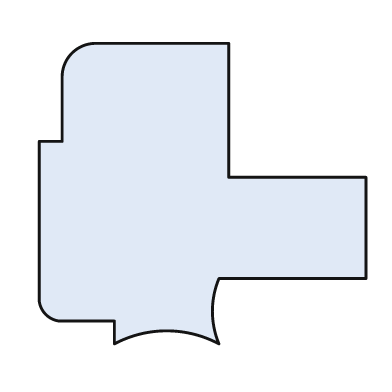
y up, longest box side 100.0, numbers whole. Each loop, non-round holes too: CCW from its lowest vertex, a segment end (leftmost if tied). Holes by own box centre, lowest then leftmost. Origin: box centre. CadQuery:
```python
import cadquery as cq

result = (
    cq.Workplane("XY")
    .moveTo(-27.0, -46.0)
    .threePointArc((-11.0, -42.0), (5.0, -46.0))
    .threePointArc((3.0, -36.0), (5.0, -26.0))
    .lineTo(50.0, -26.0)
    .lineTo(50.0, 5.0)
    .lineTo(8.0, 5.0)
    .lineTo(8.0, 46.0)
    .lineTo(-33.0, 46.0)
    .threePointArc((-40.0, 43.0), (-43.0, 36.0))
    .lineTo(-43.0, 16.0)
    .lineTo(-50.0, 16.0)
    .lineTo(-50.0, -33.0)
    .threePointArc((-48.0, -37.0), (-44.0, -39.0))
    .lineTo(-27.0, -39.0)
    .close()
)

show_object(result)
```